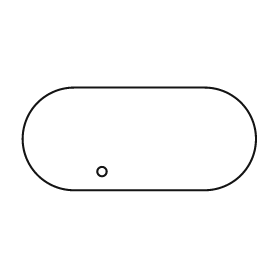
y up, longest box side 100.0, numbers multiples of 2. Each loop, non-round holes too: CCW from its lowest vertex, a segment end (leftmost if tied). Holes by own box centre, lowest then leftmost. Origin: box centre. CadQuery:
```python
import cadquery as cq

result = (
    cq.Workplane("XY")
    .moveTo(-28.0, -22.0)
    .lineTo(28.0, -22.0)
    .threePointArc((50.0, 0.0), (28.0, 22.0))
    .lineTo(-28.0, 22.0)
    .threePointArc((-50.0, 0.0), (-28.0, -22.0))
    .close()
    .moveTo(-16.0, -14.0)
    .circle(2.0)
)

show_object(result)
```